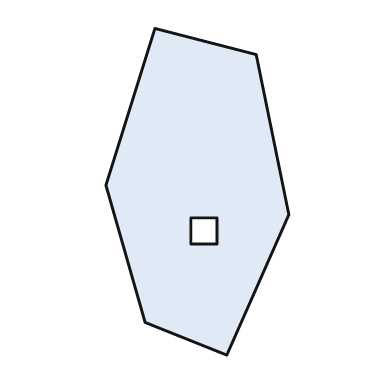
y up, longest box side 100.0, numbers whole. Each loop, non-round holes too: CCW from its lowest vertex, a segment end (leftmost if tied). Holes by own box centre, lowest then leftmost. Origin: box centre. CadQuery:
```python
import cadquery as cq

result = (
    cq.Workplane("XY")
    .moveTo(9.0, -50.0)
    .lineTo(28.0, -7.0)
    .lineTo(18.0, 42.0)
    .lineTo(-13.0, 50.0)
    .lineTo(-28.0, 2.0)
    .lineTo(-16.0, -40.0)
    .close()
    .moveTo(-2.0, -16.0)
    .lineTo(6.0, -16.0)
    .lineTo(6.0, -8.0)
    .lineTo(-2.0, -8.0)
    .close()
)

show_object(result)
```